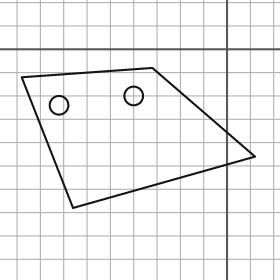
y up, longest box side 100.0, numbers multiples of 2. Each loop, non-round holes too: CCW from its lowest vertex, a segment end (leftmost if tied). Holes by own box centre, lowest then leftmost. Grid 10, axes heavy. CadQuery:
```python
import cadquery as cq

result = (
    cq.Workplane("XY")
    .moveTo(-66.0, -68.0)
    .lineTo(12.0, -46.0)
    .lineTo(-32.0, -8.0)
    .lineTo(-88.0, -12.0)
    .close()
    .moveTo(-72.0, -24.0)
    .circle(4.0)
    .moveTo(-40.0, -20.0)
    .circle(4.0)
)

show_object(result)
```